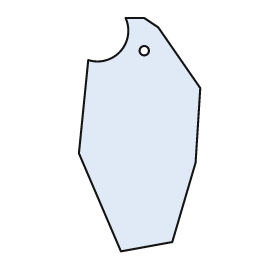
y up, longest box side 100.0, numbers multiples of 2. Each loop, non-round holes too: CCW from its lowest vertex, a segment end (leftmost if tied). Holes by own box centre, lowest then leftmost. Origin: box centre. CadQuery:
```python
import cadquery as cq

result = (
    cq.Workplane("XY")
    .moveTo(-8.0, -50.0)
    .lineTo(14.0, -46.0)
    .lineTo(24.0, -12.0)
    .lineTo(26.0, 20.0)
    .lineTo(8.0, 46.0)
    .lineTo(2.0, 50.0)
    .lineTo(-6.0, 50.0)
    .threePointArc((-8.0, 36.0), (-22.0, 32.0))
    .lineTo(-26.0, -8.0)
    .close()
    .moveTo(2.0, 36.0)
    .circle(2.0)
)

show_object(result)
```